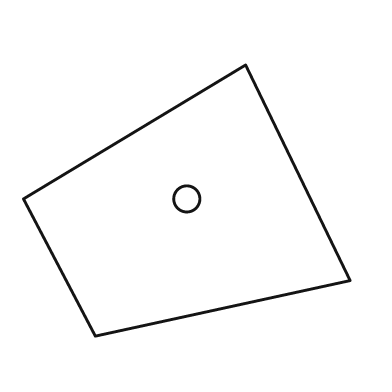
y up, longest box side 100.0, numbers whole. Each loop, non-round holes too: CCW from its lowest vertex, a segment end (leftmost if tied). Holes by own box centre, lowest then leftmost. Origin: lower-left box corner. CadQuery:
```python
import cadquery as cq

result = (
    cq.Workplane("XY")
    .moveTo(22.0, 0.0)
    .lineTo(100.0, 17.0)
    .lineTo(68.0, 83.0)
    .lineTo(0.0, 42.0)
    .close()
    .moveTo(50.0, 42.0)
    .circle(4.0)
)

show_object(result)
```